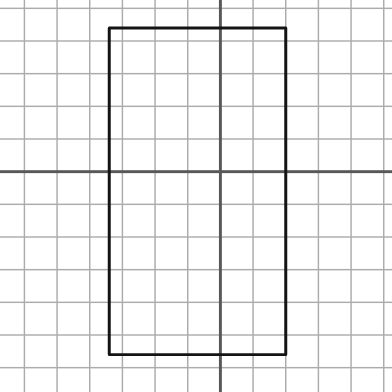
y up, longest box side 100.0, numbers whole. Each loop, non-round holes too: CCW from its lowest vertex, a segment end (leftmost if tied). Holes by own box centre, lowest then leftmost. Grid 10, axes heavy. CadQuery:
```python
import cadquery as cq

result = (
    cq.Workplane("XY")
    .moveTo(-34.0, -56.0)
    .lineTo(20.0, -56.0)
    .lineTo(20.0, 44.0)
    .lineTo(-34.0, 44.0)
    .close()
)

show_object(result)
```